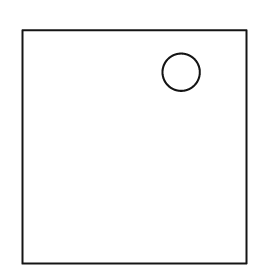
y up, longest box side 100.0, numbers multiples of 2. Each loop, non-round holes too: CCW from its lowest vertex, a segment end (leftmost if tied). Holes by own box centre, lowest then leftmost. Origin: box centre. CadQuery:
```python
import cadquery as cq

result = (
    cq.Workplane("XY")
    .moveTo(-48.0, -50.0)
    .lineTo(48.0, -50.0)
    .lineTo(48.0, 50.0)
    .lineTo(-48.0, 50.0)
    .close()
    .moveTo(20.0, 32.0)
    .circle(8.0)
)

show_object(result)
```